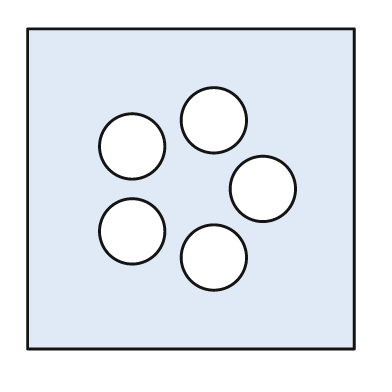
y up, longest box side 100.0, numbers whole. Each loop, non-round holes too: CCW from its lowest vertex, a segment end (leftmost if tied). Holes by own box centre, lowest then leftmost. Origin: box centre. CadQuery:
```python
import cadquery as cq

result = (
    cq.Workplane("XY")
    .moveTo(-50.0, -49.0)
    .lineTo(50.0, -49.0)
    .lineTo(50.0, 49.0)
    .lineTo(-50.0, 49.0)
    .close()
    .moveTo(7.0, -21.0)
    .circle(10.0)
    .moveTo(-18.0, -13.0)
    .circle(10.0)
    .moveTo(22.0, 0.0)
    .circle(10.0)
    .moveTo(-18.0, 13.0)
    .circle(10.0)
    .moveTo(7.0, 21.0)
    .circle(10.0)
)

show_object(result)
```